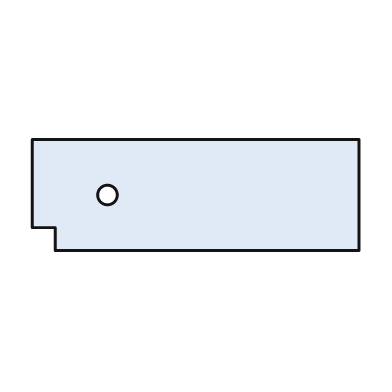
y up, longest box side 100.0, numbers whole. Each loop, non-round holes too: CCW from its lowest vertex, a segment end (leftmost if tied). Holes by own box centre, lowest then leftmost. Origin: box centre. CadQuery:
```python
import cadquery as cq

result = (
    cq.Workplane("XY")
    .moveTo(-43.0, -17.0)
    .lineTo(50.0, -17.0)
    .lineTo(50.0, 17.0)
    .lineTo(-50.0, 17.0)
    .lineTo(-50.0, -10.0)
    .lineTo(-43.0, -10.0)
    .close()
    .moveTo(-27.0, 0.0)
    .circle(3.0)
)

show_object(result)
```